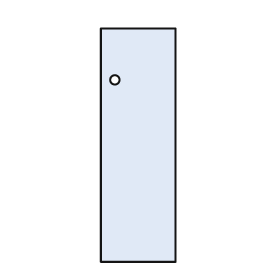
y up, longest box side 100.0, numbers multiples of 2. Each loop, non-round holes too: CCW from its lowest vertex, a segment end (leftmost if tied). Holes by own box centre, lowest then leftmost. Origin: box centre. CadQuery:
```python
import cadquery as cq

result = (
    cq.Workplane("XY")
    .moveTo(-16.0, -50.0)
    .lineTo(16.0, -50.0)
    .lineTo(16.0, 50.0)
    .lineTo(-16.0, 50.0)
    .close()
    .moveTo(-10.0, 28.0)
    .circle(2.0)
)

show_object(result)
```